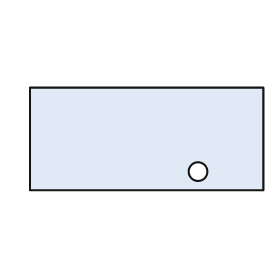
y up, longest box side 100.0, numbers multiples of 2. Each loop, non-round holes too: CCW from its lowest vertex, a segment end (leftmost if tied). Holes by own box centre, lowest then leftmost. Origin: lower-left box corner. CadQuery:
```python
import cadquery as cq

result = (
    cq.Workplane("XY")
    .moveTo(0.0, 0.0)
    .lineTo(100.0, 0.0)
    .lineTo(100.0, 44.0)
    .lineTo(0.0, 44.0)
    .close()
    .moveTo(72.0, 8.0)
    .circle(4.0)
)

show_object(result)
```